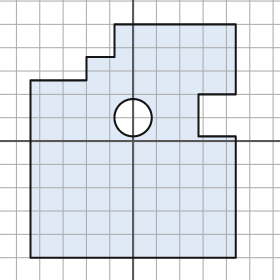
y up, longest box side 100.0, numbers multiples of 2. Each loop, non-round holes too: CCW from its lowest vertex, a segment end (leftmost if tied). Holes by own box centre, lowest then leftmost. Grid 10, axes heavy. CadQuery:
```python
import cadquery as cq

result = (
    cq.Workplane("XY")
    .moveTo(-44.0, -50.0)
    .lineTo(44.0, -50.0)
    .lineTo(44.0, 2.0)
    .lineTo(28.0, 2.0)
    .lineTo(28.0, 20.0)
    .lineTo(44.0, 20.0)
    .lineTo(44.0, 50.0)
    .lineTo(-8.0, 50.0)
    .lineTo(-8.0, 36.0)
    .lineTo(-20.0, 36.0)
    .lineTo(-20.0, 26.0)
    .lineTo(-44.0, 26.0)
    .close()
    .moveTo(0.0, 10.0)
    .circle(8.0)
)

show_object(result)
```